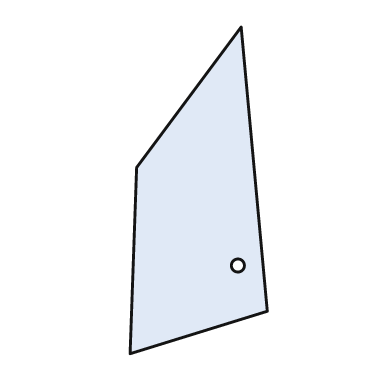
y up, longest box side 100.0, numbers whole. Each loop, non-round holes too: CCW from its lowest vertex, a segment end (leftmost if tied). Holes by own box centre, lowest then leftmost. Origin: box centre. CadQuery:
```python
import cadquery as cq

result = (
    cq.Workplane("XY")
    .moveTo(-21.0, -50.0)
    .lineTo(21.0, -37.0)
    .lineTo(13.0, 50.0)
    .lineTo(-19.0, 7.0)
    .close()
    .moveTo(12.0, -23.0)
    .circle(2.0)
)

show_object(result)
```